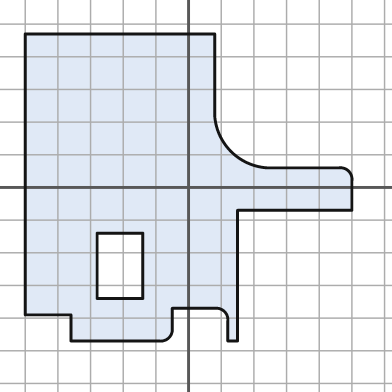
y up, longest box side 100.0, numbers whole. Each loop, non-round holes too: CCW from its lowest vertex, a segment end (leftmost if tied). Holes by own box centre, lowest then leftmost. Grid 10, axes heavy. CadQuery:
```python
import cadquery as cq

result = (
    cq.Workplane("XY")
    .moveTo(-36.0, -47.0)
    .lineTo(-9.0, -47.0)
    .threePointArc((-6.0, -46.0), (-5.0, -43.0))
    .lineTo(-5.0, -37.0)
    .lineTo(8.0, -37.0)
    .threePointArc((11.0, -38.0), (12.0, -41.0))
    .lineTo(12.0, -47.0)
    .lineTo(15.0, -47.0)
    .lineTo(15.0, -7.0)
    .lineTo(50.0, -7.0)
    .lineTo(50.0, 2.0)
    .threePointArc((49.0, 5.0), (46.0, 6.0))
    .lineTo(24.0, 6.0)
    .threePointArc((13.0, 11.0), (8.0, 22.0))
    .lineTo(8.0, 47.0)
    .lineTo(-50.0, 47.0)
    .lineTo(-50.0, -39.0)
    .lineTo(-36.0, -39.0)
    .close()
    .moveTo(-28.0, -34.0)
    .lineTo(-14.0, -34.0)
    .lineTo(-14.0, -14.0)
    .lineTo(-28.0, -14.0)
    .close()
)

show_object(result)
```